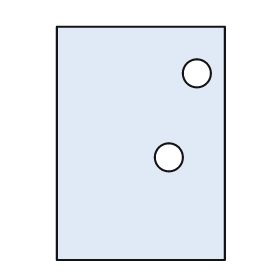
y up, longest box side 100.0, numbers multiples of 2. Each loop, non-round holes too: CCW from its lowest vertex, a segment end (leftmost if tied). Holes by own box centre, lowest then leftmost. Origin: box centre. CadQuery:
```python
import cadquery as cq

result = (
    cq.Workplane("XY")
    .moveTo(-36.0, -50.0)
    .lineTo(36.0, -50.0)
    .lineTo(36.0, 50.0)
    .lineTo(-36.0, 50.0)
    .close()
    .moveTo(12.0, -6.0)
    .circle(6.0)
    .moveTo(24.0, 30.0)
    .circle(6.0)
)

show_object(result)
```